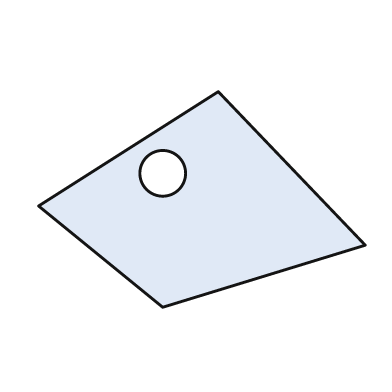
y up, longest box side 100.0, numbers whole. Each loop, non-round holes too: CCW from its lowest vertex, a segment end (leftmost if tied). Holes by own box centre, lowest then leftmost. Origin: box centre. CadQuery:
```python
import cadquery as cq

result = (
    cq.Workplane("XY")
    .moveTo(-12.0, -33.0)
    .lineTo(50.0, -14.0)
    .lineTo(5.0, 33.0)
    .lineTo(-50.0, -2.0)
    .close()
    .moveTo(-12.0, 8.0)
    .circle(7.0)
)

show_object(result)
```